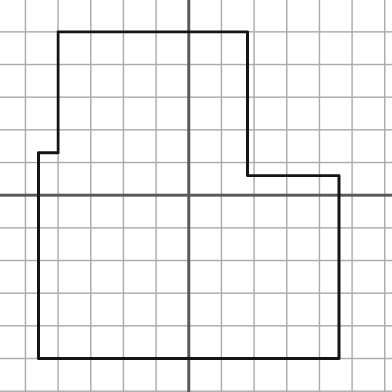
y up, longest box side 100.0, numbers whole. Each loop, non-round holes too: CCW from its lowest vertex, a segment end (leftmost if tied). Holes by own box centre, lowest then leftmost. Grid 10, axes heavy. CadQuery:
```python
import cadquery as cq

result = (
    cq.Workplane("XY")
    .moveTo(-46.0, -50.0)
    .lineTo(46.0, -50.0)
    .lineTo(46.0, 6.0)
    .lineTo(18.0, 6.0)
    .lineTo(18.0, 50.0)
    .lineTo(-40.0, 50.0)
    .lineTo(-40.0, 13.0)
    .lineTo(-46.0, 13.0)
    .close()
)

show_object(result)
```